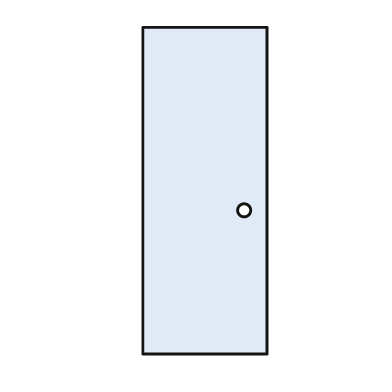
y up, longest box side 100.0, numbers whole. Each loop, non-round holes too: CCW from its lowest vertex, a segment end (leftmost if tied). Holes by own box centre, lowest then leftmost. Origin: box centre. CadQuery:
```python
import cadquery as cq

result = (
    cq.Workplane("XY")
    .moveTo(-19.0, -50.0)
    .lineTo(19.0, -50.0)
    .lineTo(19.0, 50.0)
    .lineTo(-19.0, 50.0)
    .close()
    .moveTo(12.0, -6.0)
    .circle(2.0)
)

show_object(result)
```